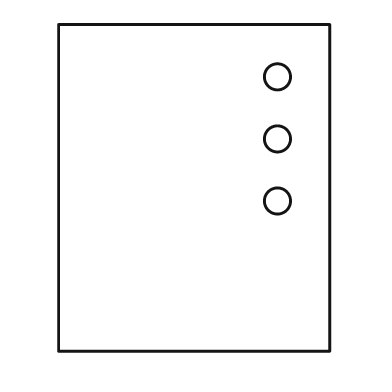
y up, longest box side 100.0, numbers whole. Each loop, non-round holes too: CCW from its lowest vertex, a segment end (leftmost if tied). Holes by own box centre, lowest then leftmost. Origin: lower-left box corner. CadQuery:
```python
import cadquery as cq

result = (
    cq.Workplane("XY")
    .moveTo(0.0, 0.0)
    .lineTo(83.0, 0.0)
    .lineTo(83.0, 100.0)
    .lineTo(0.0, 100.0)
    .close()
    .moveTo(67.0, 46.0)
    .circle(4.0)
    .moveTo(67.0, 65.0)
    .circle(4.0)
    .moveTo(67.0, 84.0)
    .circle(4.0)
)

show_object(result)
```